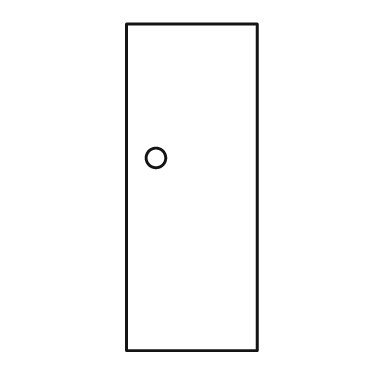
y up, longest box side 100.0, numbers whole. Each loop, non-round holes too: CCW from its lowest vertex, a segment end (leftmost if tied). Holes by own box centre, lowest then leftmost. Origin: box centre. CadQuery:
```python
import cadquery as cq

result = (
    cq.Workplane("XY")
    .moveTo(-20.0, -50.0)
    .lineTo(20.0, -50.0)
    .lineTo(20.0, 50.0)
    .lineTo(-20.0, 50.0)
    .close()
    .moveTo(-11.0, 9.0)
    .circle(3.0)
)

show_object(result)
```